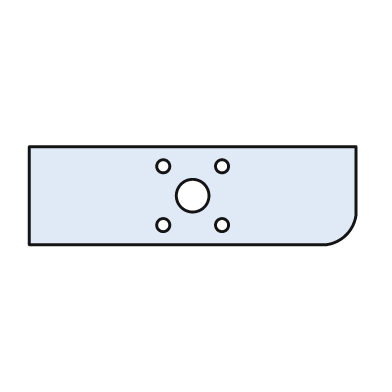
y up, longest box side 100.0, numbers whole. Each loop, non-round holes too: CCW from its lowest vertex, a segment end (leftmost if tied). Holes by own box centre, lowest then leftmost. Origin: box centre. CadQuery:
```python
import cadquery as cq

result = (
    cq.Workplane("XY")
    .moveTo(-50.0, -15.0)
    .lineTo(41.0, -15.0)
    .threePointArc((47.0, -12.0), (50.0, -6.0))
    .lineTo(50.0, 15.0)
    .lineTo(-50.0, 15.0)
    .close()
    .moveTo(-9.0, -9.0)
    .circle(2.0)
    .moveTo(9.0, -9.0)
    .circle(2.0)
    .moveTo(0.0, 0.0)
    .circle(5.0)
    .moveTo(-9.0, 9.0)
    .circle(2.0)
    .moveTo(9.0, 9.0)
    .circle(2.0)
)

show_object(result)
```